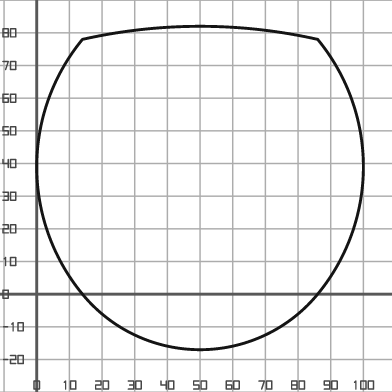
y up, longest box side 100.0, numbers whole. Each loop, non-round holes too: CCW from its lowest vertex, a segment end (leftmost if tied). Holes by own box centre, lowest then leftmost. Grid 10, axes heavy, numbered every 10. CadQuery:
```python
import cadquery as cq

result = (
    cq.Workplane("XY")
    .moveTo(14.0, 0.0)
    .threePointArc((50.0, -17.0), (86.0, 0.0))
    .threePointArc((100.0, 39.0), (86.0, 78.0))
    .threePointArc((50.0, 82.0), (14.0, 78.0))
    .threePointArc((0.0, 39.0), (14.0, 0.0))
    .close()
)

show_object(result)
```